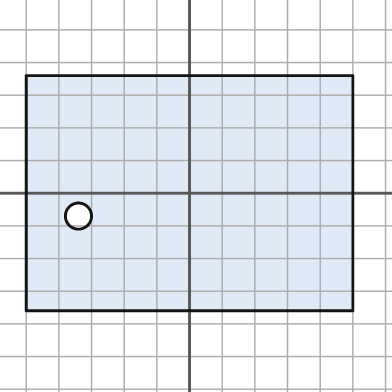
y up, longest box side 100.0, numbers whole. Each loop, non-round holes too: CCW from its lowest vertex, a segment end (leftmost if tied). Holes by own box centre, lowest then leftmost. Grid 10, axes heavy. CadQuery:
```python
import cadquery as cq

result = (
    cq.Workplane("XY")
    .moveTo(-50.0, -36.0)
    .lineTo(50.0, -36.0)
    .lineTo(50.0, 36.0)
    .lineTo(-50.0, 36.0)
    .close()
    .moveTo(-34.0, -7.0)
    .circle(4.0)
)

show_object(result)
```